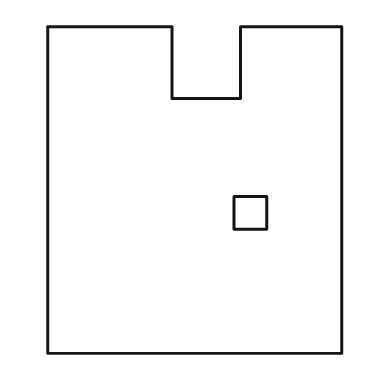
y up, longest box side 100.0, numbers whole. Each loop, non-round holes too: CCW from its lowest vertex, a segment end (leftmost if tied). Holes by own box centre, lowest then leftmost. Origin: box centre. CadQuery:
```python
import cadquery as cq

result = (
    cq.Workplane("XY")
    .moveTo(-45.0, -50.0)
    .lineTo(45.0, -50.0)
    .lineTo(45.0, 50.0)
    .lineTo(14.0, 50.0)
    .lineTo(14.0, 28.0)
    .lineTo(-7.0, 28.0)
    .lineTo(-7.0, 50.0)
    .lineTo(-45.0, 50.0)
    .close()
    .moveTo(12.0, -12.0)
    .lineTo(22.0, -12.0)
    .lineTo(22.0, -2.0)
    .lineTo(12.0, -2.0)
    .close()
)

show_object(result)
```